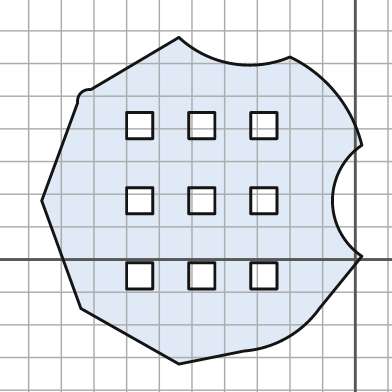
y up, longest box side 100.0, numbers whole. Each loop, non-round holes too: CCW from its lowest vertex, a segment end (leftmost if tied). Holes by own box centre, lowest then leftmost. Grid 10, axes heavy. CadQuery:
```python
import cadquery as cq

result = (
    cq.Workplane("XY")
    .moveTo(-54.0, -32.0)
    .lineTo(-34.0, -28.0)
    .threePointArc((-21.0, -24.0), (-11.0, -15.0))
    .lineTo(2.0, 1.0)
    .threePointArc((-7.0, 18.0), (2.0, 35.0))
    .threePointArc((-6.0, 51.0), (-20.0, 62.0))
    .threePointArc((-38.0, 60.0), (-54.0, 68.0))
    .lineTo(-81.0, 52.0)
    .threePointArc((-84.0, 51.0), (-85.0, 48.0))
    .lineTo(-96.0, 18.0)
    .lineTo(-84.0, -15.0)
    .close()
    .moveTo(-70.0, -9.0)
    .lineTo(-62.0, -9.0)
    .lineTo(-62.0, -1.0)
    .lineTo(-70.0, -1.0)
    .close()
    .moveTo(-51.0, -9.0)
    .lineTo(-43.0, -9.0)
    .lineTo(-43.0, -1.0)
    .lineTo(-51.0, -1.0)
    .close()
    .moveTo(-32.0, -9.0)
    .lineTo(-24.0, -9.0)
    .lineTo(-24.0, -1.0)
    .lineTo(-32.0, -1.0)
    .close()
    .moveTo(-70.0, 14.0)
    .lineTo(-62.0, 14.0)
    .lineTo(-62.0, 22.0)
    .lineTo(-70.0, 22.0)
    .close()
    .moveTo(-51.0, 14.0)
    .lineTo(-43.0, 14.0)
    .lineTo(-43.0, 22.0)
    .lineTo(-51.0, 22.0)
    .close()
    .moveTo(-32.0, 14.0)
    .lineTo(-24.0, 14.0)
    .lineTo(-24.0, 22.0)
    .lineTo(-32.0, 22.0)
    .close()
    .moveTo(-70.0, 37.0)
    .lineTo(-62.0, 37.0)
    .lineTo(-62.0, 45.0)
    .lineTo(-70.0, 45.0)
    .close()
    .moveTo(-51.0, 37.0)
    .lineTo(-43.0, 37.0)
    .lineTo(-43.0, 45.0)
    .lineTo(-51.0, 45.0)
    .close()
    .moveTo(-32.0, 37.0)
    .lineTo(-24.0, 37.0)
    .lineTo(-24.0, 45.0)
    .lineTo(-32.0, 45.0)
    .close()
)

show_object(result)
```